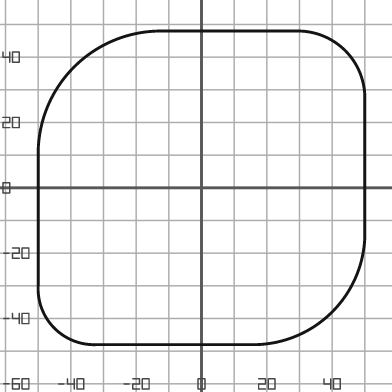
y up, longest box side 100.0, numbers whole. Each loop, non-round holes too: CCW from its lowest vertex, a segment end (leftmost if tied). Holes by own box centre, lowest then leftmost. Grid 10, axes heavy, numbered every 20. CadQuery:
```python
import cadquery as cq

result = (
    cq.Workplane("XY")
    .moveTo(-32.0, -48.0)
    .lineTo(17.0, -48.0)
    .threePointArc((40.0, -38.0), (50.0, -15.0))
    .lineTo(50.0, 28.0)
    .threePointArc((44.0, 42.0), (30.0, 48.0))
    .lineTo(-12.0, 48.0)
    .threePointArc((-39.0, 37.0), (-50.0, 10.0))
    .lineTo(-50.0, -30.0)
    .threePointArc((-45.0, -43.0), (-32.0, -48.0))
    .close()
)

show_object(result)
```